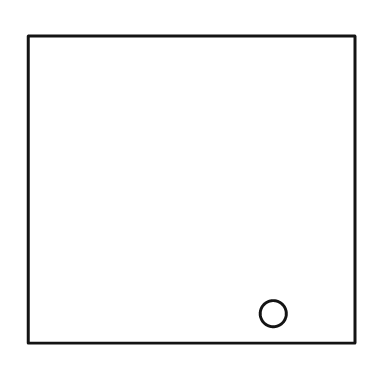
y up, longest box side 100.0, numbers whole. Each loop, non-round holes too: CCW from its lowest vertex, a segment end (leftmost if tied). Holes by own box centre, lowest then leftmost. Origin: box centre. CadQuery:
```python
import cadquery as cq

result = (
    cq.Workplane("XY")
    .moveTo(-50.0, -47.0)
    .lineTo(50.0, -47.0)
    .lineTo(50.0, 47.0)
    .lineTo(-50.0, 47.0)
    .close()
    .moveTo(25.0, -38.0)
    .circle(4.0)
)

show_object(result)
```